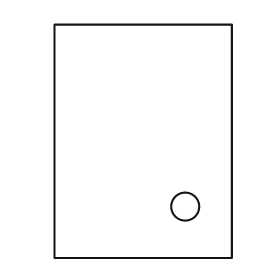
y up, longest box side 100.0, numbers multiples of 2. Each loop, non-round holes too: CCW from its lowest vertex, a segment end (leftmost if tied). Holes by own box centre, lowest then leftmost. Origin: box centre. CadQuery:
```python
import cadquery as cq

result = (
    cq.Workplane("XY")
    .moveTo(-38.0, -50.0)
    .lineTo(38.0, -50.0)
    .lineTo(38.0, 50.0)
    .lineTo(-38.0, 50.0)
    .close()
    .moveTo(18.0, -28.0)
    .circle(6.0)
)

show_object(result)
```